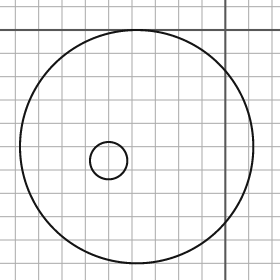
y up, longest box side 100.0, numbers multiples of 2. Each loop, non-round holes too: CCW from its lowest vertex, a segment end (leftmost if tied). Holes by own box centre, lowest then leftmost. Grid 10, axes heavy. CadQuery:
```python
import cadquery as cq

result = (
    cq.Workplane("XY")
    .moveTo(-38.0, -50.0)
    .circle(50.0)
    .moveTo(-50.0, -56.0)
    .circle(8.0)
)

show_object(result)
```